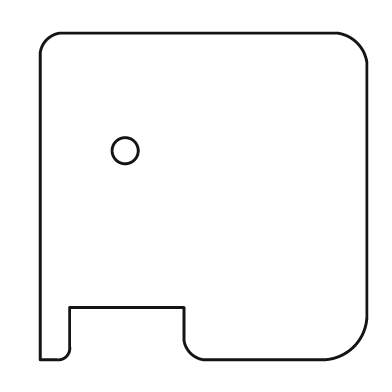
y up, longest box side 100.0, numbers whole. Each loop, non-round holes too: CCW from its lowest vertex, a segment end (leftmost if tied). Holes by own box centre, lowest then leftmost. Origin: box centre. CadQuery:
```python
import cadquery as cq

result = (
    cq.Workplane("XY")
    .moveTo(-50.0, -50.0)
    .lineTo(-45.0, -50.0)
    .threePointArc((-42.0, -49.0), (-41.0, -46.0))
    .lineTo(-41.0, -34.0)
    .lineTo(-6.0, -34.0)
    .lineTo(-6.0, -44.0)
    .threePointArc((-4.0, -48.0), (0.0, -50.0))
    .lineTo(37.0, -50.0)
    .threePointArc((46.0, -46.0), (50.0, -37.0))
    .lineTo(50.0, 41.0)
    .threePointArc((47.0, 47.0), (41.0, 50.0))
    .lineTo(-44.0, 50.0)
    .threePointArc((-48.0, 48.0), (-50.0, 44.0))
    .close()
    .moveTo(-24.0, 14.0)
    .circle(4.0)
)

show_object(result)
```